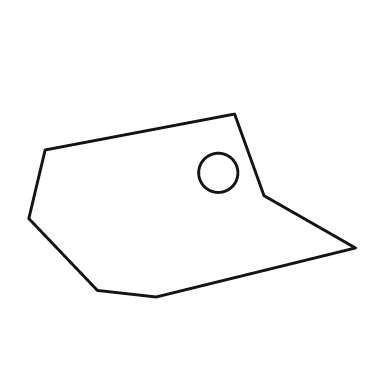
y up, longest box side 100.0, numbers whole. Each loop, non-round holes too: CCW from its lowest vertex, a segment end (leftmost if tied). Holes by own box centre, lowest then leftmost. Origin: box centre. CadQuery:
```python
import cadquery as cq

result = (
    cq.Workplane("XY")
    .moveTo(-11.0, -28.0)
    .lineTo(50.0, -13.0)
    .lineTo(22.0, 3.0)
    .lineTo(13.0, 28.0)
    .lineTo(-45.0, 17.0)
    .lineTo(-50.0, -4.0)
    .lineTo(-29.0, -26.0)
    .close()
    .moveTo(8.0, 10.0)
    .circle(6.0)
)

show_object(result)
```